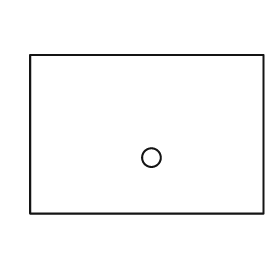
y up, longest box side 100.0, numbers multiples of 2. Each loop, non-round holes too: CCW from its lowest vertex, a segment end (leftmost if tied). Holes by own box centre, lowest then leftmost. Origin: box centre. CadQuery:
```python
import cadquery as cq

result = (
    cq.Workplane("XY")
    .moveTo(-50.0, -34.0)
    .lineTo(50.0, -34.0)
    .lineTo(50.0, 34.0)
    .lineTo(-50.0, 34.0)
    .close()
    .moveTo(2.0, -10.0)
    .circle(4.0)
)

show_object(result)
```